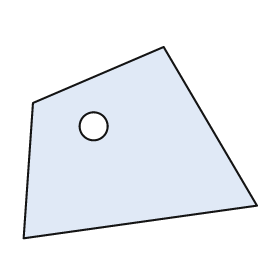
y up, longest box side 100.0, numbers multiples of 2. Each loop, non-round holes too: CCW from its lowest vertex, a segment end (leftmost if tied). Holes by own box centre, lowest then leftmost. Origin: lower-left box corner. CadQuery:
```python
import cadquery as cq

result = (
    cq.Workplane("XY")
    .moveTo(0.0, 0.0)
    .lineTo(100.0, 14.0)
    .lineTo(60.0, 82.0)
    .lineTo(4.0, 58.0)
    .close()
    .moveTo(30.0, 48.0)
    .circle(6.0)
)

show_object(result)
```